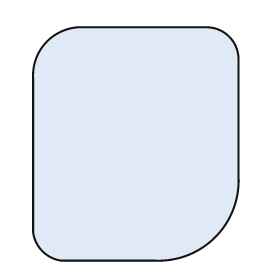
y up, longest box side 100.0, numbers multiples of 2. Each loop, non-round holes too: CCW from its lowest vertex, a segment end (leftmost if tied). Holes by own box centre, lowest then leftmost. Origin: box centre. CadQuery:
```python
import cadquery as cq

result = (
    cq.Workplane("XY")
    .moveTo(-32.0, -50.0)
    .lineTo(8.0, -50.0)
    .threePointArc((34.0, -40.0), (44.0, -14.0))
    .lineTo(44.0, 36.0)
    .threePointArc((40.0, 46.0), (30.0, 50.0))
    .lineTo(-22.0, 50.0)
    .threePointArc((-38.0, 44.0), (-44.0, 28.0))
    .lineTo(-44.0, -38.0)
    .threePointArc((-40.0, -46.0), (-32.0, -50.0))
    .close()
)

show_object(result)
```